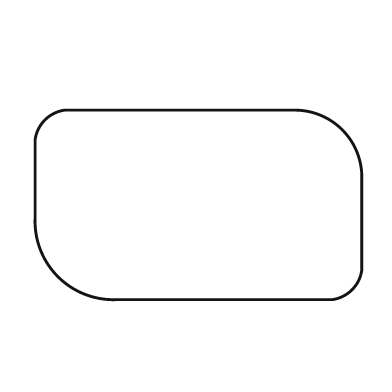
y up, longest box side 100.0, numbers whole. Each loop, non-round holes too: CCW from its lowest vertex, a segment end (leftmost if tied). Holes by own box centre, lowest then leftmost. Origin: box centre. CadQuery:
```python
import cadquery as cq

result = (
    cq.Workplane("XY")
    .moveTo(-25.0, -29.0)
    .lineTo(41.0, -29.0)
    .threePointArc((47.0, -26.0), (50.0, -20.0))
    .lineTo(50.0, 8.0)
    .threePointArc((44.0, 23.0), (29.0, 29.0))
    .lineTo(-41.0, 29.0)
    .threePointArc((-47.0, 26.0), (-50.0, 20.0))
    .lineTo(-50.0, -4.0)
    .threePointArc((-43.0, -22.0), (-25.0, -29.0))
    .close()
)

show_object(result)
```